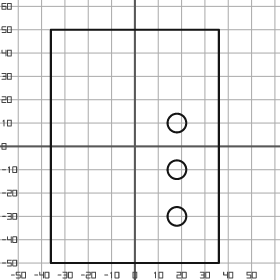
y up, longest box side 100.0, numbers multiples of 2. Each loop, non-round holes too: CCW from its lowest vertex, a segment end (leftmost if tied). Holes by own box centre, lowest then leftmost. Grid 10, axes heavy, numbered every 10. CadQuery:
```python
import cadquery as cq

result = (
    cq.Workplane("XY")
    .moveTo(-36.0, -50.0)
    .lineTo(36.0, -50.0)
    .lineTo(36.0, 50.0)
    .lineTo(-36.0, 50.0)
    .close()
    .moveTo(18.0, -30.0)
    .circle(4.0)
    .moveTo(18.0, -10.0)
    .circle(4.0)
    .moveTo(18.0, 10.0)
    .circle(4.0)
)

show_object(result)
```